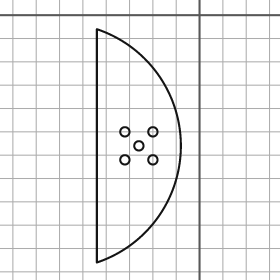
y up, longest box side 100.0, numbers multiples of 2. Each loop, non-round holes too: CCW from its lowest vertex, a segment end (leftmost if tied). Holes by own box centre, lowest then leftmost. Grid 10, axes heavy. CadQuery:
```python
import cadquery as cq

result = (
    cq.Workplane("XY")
    .moveTo(-44.0, -106.0)
    .threePointArc((-8.0, -56.0), (-44.0, -6.0))
    .close()
    .moveTo(-32.0, -62.0)
    .circle(2.0)
    .moveTo(-20.0, -62.0)
    .circle(2.0)
    .moveTo(-26.0, -56.0)
    .circle(2.0)
    .moveTo(-32.0, -50.0)
    .circle(2.0)
    .moveTo(-20.0, -50.0)
    .circle(2.0)
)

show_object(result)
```